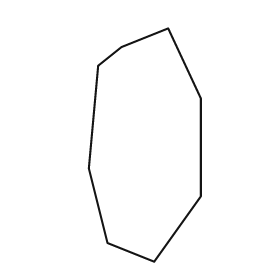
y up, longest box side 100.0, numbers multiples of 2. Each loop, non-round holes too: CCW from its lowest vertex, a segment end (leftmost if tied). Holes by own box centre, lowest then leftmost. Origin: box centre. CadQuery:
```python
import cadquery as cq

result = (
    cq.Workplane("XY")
    .moveTo(4.0, -50.0)
    .lineTo(24.0, -22.0)
    .lineTo(24.0, 20.0)
    .lineTo(10.0, 50.0)
    .lineTo(-10.0, 42.0)
    .lineTo(-20.0, 34.0)
    .lineTo(-24.0, -10.0)
    .lineTo(-16.0, -42.0)
    .close()
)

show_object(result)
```